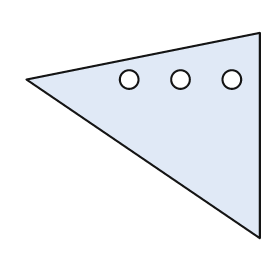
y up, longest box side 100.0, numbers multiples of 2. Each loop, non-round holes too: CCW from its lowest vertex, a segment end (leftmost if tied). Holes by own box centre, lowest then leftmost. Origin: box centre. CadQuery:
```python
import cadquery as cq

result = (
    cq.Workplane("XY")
    .moveTo(50.0, -44.0)
    .lineTo(50.0, 44.0)
    .lineTo(-50.0, 24.0)
    .close()
    .moveTo(-6.0, 24.0)
    .circle(4.0)
    .moveTo(16.0, 24.0)
    .circle(4.0)
    .moveTo(38.0, 24.0)
    .circle(4.0)
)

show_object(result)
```